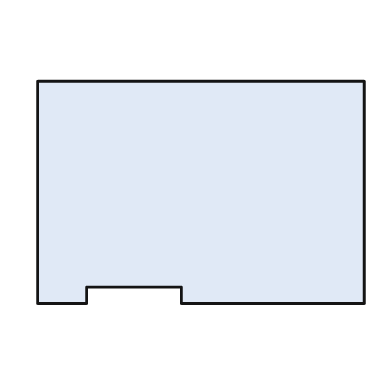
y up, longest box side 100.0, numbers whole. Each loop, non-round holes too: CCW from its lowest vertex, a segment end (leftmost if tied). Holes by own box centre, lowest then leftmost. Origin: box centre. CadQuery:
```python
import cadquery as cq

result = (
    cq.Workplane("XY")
    .moveTo(-50.0, -34.0)
    .lineTo(-35.0, -34.0)
    .lineTo(-35.0, -29.0)
    .lineTo(-6.0, -29.0)
    .lineTo(-6.0, -34.0)
    .lineTo(50.0, -34.0)
    .lineTo(50.0, 34.0)
    .lineTo(-50.0, 34.0)
    .close()
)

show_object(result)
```